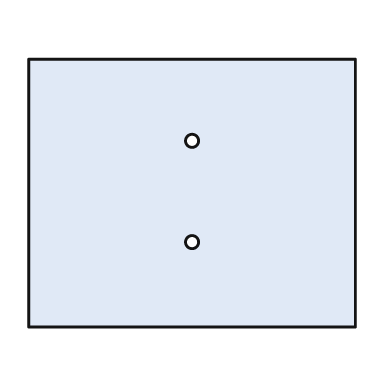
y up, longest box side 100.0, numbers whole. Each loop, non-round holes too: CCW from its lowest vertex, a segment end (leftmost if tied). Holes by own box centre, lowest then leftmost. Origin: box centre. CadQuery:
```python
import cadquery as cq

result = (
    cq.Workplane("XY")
    .moveTo(-50.0, -41.0)
    .lineTo(50.0, -41.0)
    .lineTo(50.0, 41.0)
    .lineTo(-50.0, 41.0)
    .close()
    .moveTo(0.0, -15.0)
    .circle(2.0)
    .moveTo(0.0, 16.0)
    .circle(2.0)
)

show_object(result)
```